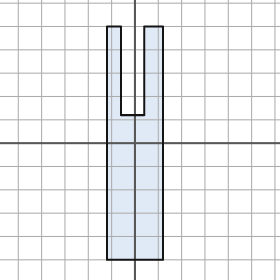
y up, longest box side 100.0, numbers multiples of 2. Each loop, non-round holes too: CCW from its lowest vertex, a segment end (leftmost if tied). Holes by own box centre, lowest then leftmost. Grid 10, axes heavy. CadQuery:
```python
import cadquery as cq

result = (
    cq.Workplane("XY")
    .moveTo(-12.0, -50.0)
    .lineTo(12.0, -50.0)
    .lineTo(12.0, 50.0)
    .lineTo(4.0, 50.0)
    .lineTo(4.0, 12.0)
    .lineTo(-6.0, 12.0)
    .lineTo(-6.0, 50.0)
    .lineTo(-12.0, 50.0)
    .close()
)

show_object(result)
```